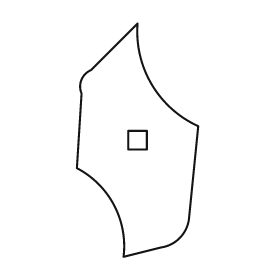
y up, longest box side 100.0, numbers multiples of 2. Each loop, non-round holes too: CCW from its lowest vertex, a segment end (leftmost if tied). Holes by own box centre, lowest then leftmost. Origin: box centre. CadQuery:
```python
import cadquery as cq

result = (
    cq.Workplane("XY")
    .moveTo(-6.0, -50.0)
    .lineTo(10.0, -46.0)
    .threePointArc((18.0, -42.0), (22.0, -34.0))
    .lineTo(26.0, 6.0)
    .threePointArc((6.0, 24.0), (0.0, 50.0))
    .lineTo(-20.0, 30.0)
    .threePointArc((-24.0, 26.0), (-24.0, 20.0))
    .lineTo(-26.0, -12.0)
    .threePointArc((-10.0, -28.0), (-6.0, -50.0))
    .close()
    .moveTo(-4.0, -4.0)
    .lineTo(4.0, -4.0)
    .lineTo(4.0, 4.0)
    .lineTo(-4.0, 4.0)
    .close()
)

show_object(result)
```